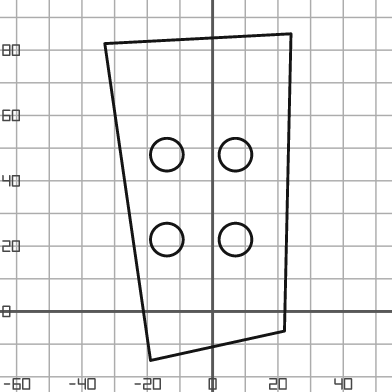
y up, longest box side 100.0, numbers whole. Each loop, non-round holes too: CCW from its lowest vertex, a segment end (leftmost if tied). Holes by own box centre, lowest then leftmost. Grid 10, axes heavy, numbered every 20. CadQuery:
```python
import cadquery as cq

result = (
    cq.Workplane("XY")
    .moveTo(-19.0, -15.0)
    .lineTo(22.0, -6.0)
    .lineTo(24.0, 85.0)
    .lineTo(-33.0, 82.0)
    .close()
    .moveTo(-14.0, 22.0)
    .circle(5.0)
    .moveTo(7.0, 22.0)
    .circle(5.0)
    .moveTo(-14.0, 48.0)
    .circle(5.0)
    .moveTo(7.0, 48.0)
    .circle(5.0)
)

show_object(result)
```